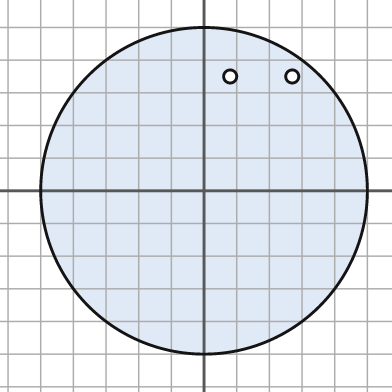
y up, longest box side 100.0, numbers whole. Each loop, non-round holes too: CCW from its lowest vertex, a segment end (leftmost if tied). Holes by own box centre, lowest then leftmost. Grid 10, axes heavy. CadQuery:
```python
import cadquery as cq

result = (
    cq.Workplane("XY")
    .moveTo(0.0, 0.0)
    .circle(50.0)
    .moveTo(8.0, 35.0)
    .circle(2.0)
    .moveTo(27.0, 35.0)
    .circle(2.0)
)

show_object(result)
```